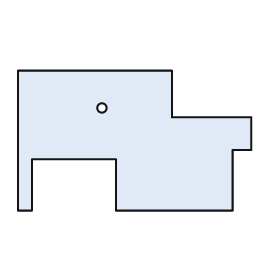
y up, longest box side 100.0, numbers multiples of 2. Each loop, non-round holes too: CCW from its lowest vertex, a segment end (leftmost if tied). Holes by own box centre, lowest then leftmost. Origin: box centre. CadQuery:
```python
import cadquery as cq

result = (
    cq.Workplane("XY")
    .moveTo(-50.0, -30.0)
    .lineTo(-44.0, -30.0)
    .lineTo(-44.0, -8.0)
    .lineTo(-8.0, -8.0)
    .lineTo(-8.0, -30.0)
    .lineTo(42.0, -30.0)
    .lineTo(42.0, -4.0)
    .lineTo(50.0, -4.0)
    .lineTo(50.0, 10.0)
    .lineTo(16.0, 10.0)
    .lineTo(16.0, 30.0)
    .lineTo(-50.0, 30.0)
    .close()
    .moveTo(-14.0, 14.0)
    .circle(2.0)
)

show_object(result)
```